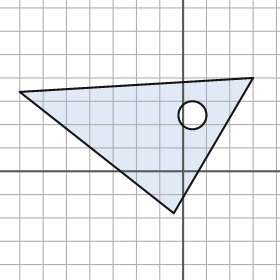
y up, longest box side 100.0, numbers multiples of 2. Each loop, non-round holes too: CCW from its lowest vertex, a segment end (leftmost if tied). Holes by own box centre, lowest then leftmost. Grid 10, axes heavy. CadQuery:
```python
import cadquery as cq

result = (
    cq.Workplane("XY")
    .moveTo(-4.0, -18.0)
    .lineTo(30.0, 40.0)
    .lineTo(-70.0, 34.0)
    .close()
    .moveTo(4.0, 24.0)
    .circle(6.0)
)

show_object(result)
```